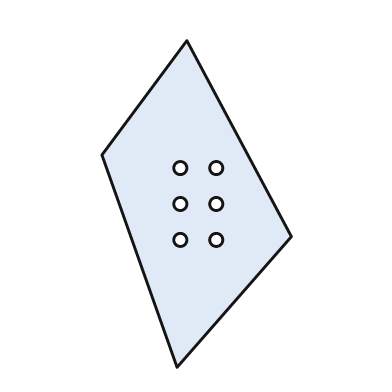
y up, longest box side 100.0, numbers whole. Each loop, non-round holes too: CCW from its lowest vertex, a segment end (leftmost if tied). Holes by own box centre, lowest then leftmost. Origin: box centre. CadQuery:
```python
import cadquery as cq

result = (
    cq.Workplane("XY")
    .moveTo(-6.0, -50.0)
    .lineTo(29.0, -10.0)
    .lineTo(-3.0, 50.0)
    .lineTo(-29.0, 15.0)
    .close()
    .moveTo(-5.0, -11.0)
    .circle(2.0)
    .moveTo(6.0, -11.0)
    .circle(2.0)
    .moveTo(-5.0, 0.0)
    .circle(2.0)
    .moveTo(6.0, 0.0)
    .circle(2.0)
    .moveTo(-5.0, 11.0)
    .circle(2.0)
    .moveTo(6.0, 11.0)
    .circle(2.0)
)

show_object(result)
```